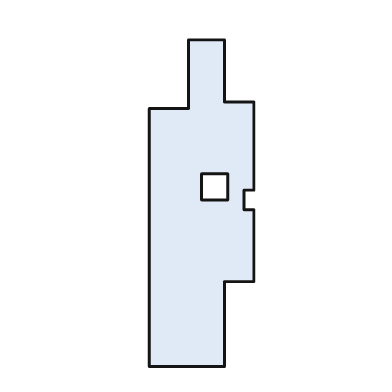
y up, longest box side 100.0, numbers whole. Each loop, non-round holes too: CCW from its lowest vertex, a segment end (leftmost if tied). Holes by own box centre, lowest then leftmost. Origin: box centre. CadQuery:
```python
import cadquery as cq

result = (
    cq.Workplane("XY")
    .moveTo(-16.0, -50.0)
    .lineTo(7.0, -50.0)
    .lineTo(7.0, -24.0)
    .lineTo(16.0, -24.0)
    .lineTo(16.0, -2.0)
    .lineTo(13.0, -2.0)
    .lineTo(13.0, 4.0)
    .lineTo(16.0, 4.0)
    .lineTo(16.0, 31.0)
    .lineTo(7.0, 31.0)
    .lineTo(7.0, 50.0)
    .lineTo(-4.0, 50.0)
    .lineTo(-4.0, 29.0)
    .lineTo(-16.0, 29.0)
    .close()
    .moveTo(0.0, 1.0)
    .lineTo(8.0, 1.0)
    .lineTo(8.0, 9.0)
    .lineTo(0.0, 9.0)
    .close()
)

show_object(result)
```